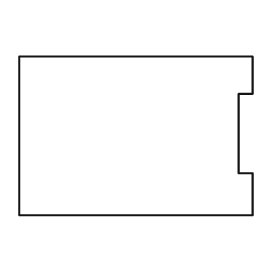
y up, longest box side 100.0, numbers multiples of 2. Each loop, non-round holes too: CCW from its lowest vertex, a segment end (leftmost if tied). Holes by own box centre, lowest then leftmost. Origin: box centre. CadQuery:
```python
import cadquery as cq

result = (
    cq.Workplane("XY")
    .moveTo(-50.0, -34.0)
    .lineTo(50.0, -34.0)
    .lineTo(50.0, -16.0)
    .lineTo(44.0, -16.0)
    .lineTo(44.0, 18.0)
    .lineTo(50.0, 18.0)
    .lineTo(50.0, 34.0)
    .lineTo(-50.0, 34.0)
    .close()
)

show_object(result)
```